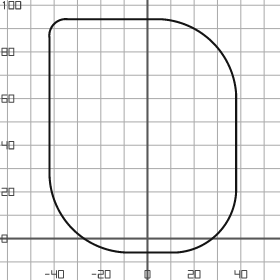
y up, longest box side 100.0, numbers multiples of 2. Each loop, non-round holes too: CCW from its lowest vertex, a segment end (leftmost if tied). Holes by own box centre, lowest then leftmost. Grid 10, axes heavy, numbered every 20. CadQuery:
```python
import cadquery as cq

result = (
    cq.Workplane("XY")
    .moveTo(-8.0, -6.0)
    .lineTo(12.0, -6.0)
    .threePointArc((30.0, 2.0), (38.0, 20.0))
    .lineTo(38.0, 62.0)
    .threePointArc((28.0, 84.0), (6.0, 94.0))
    .lineTo(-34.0, 94.0)
    .threePointArc((-40.0, 92.0), (-42.0, 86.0))
    .lineTo(-42.0, 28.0)
    .threePointArc((-32.0, 4.0), (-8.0, -6.0))
    .close()
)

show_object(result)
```